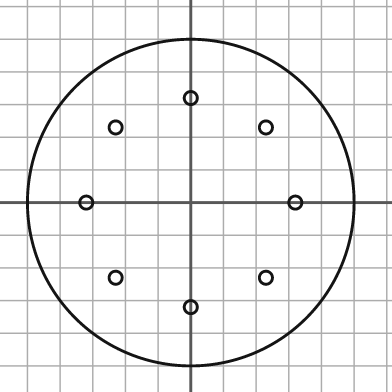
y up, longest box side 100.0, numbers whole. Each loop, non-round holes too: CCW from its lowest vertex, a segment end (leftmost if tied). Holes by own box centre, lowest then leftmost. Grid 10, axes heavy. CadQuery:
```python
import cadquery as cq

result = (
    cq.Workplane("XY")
    .moveTo(0.0, 0.0)
    .circle(50.0)
    .moveTo(0.0, -32.0)
    .circle(2.0)
    .moveTo(-23.0, -23.0)
    .circle(2.0)
    .moveTo(23.0, -23.0)
    .circle(2.0)
    .moveTo(-32.0, 0.0)
    .circle(2.0)
    .moveTo(32.0, 0.0)
    .circle(2.0)
    .moveTo(-23.0, 23.0)
    .circle(2.0)
    .moveTo(23.0, 23.0)
    .circle(2.0)
    .moveTo(0.0, 32.0)
    .circle(2.0)
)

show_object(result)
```